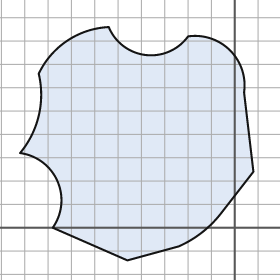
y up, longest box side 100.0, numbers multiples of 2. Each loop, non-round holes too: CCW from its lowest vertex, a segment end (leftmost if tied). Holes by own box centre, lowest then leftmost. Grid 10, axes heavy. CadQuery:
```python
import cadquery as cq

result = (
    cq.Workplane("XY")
    .moveTo(-46.0, -14.0)
    .lineTo(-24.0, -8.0)
    .threePointArc((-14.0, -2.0), (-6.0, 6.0))
    .lineTo(8.0, 24.0)
    .lineTo(4.0, 58.0)
    .threePointArc((-2.0, 76.0), (-20.0, 82.0))
    .threePointArc((-38.0, 74.0), (-54.0, 86.0))
    .threePointArc((-72.0, 80.0), (-84.0, 66.0))
    .threePointArc((-84.0, 48.0), (-92.0, 32.0))
    .threePointArc((-76.0, 20.0), (-78.0, 0.0))
    .close()
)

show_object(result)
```